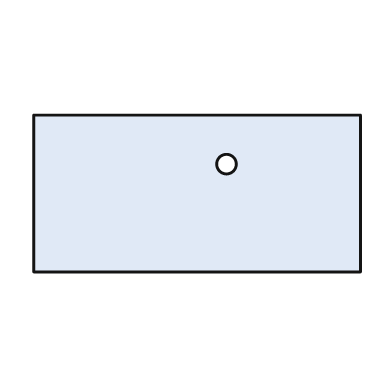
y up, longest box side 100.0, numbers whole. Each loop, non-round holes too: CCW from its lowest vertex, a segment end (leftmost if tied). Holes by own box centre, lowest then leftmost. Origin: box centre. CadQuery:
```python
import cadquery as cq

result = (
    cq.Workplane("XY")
    .moveTo(-50.0, -24.0)
    .lineTo(50.0, -24.0)
    .lineTo(50.0, 24.0)
    .lineTo(-50.0, 24.0)
    .close()
    .moveTo(9.0, 9.0)
    .circle(3.0)
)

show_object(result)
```